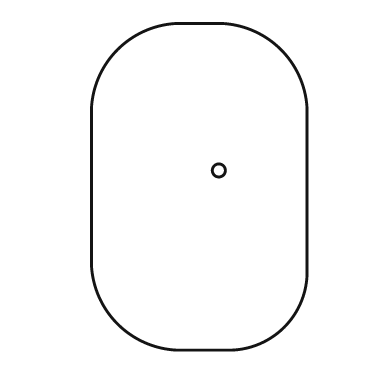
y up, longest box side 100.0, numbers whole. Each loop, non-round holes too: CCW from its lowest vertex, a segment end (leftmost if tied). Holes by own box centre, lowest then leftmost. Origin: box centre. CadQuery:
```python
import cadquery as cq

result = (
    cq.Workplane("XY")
    .moveTo(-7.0, -50.0)
    .lineTo(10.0, -50.0)
    .threePointArc((26.0, -43.0), (33.0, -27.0))
    .lineTo(33.0, 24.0)
    .threePointArc((25.0, 42.0), (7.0, 50.0))
    .lineTo(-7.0, 50.0)
    .threePointArc((-25.0, 42.0), (-33.0, 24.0))
    .lineTo(-33.0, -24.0)
    .threePointArc((-25.0, -42.0), (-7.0, -50.0))
    .close()
    .moveTo(6.0, 5.0)
    .circle(2.0)
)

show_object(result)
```